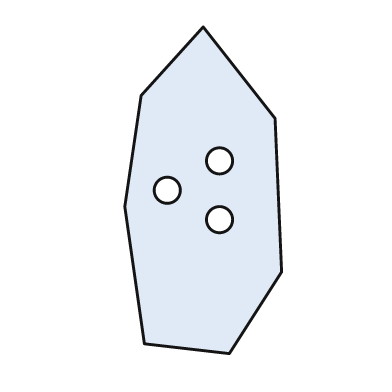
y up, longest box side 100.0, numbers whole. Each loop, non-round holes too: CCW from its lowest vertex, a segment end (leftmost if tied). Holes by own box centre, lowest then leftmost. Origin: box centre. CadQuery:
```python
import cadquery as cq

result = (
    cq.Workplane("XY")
    .moveTo(8.0, -50.0)
    .lineTo(24.0, -25.0)
    .lineTo(22.0, 22.0)
    .lineTo(0.0, 50.0)
    .lineTo(-19.0, 29.0)
    .lineTo(-24.0, -5.0)
    .lineTo(-18.0, -47.0)
    .close()
    .moveTo(5.0, -9.0)
    .circle(4.0)
    .moveTo(-11.0, 0.0)
    .circle(4.0)
    .moveTo(5.0, 9.0)
    .circle(4.0)
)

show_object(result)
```